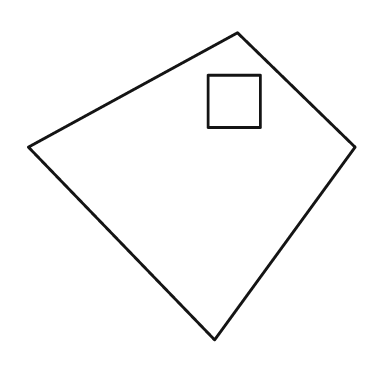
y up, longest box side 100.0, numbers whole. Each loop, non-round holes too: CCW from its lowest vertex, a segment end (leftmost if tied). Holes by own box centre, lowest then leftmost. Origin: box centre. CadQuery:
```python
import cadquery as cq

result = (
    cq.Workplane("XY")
    .moveTo(7.0, -47.0)
    .lineTo(50.0, 12.0)
    .lineTo(14.0, 47.0)
    .lineTo(-50.0, 12.0)
    .close()
    .moveTo(5.0, 18.0)
    .lineTo(21.0, 18.0)
    .lineTo(21.0, 34.0)
    .lineTo(5.0, 34.0)
    .close()
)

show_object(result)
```